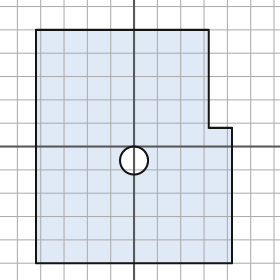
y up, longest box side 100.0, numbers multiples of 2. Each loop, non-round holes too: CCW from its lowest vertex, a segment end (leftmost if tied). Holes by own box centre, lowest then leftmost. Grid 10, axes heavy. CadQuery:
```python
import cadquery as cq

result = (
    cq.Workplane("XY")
    .moveTo(-42.0, -50.0)
    .lineTo(42.0, -50.0)
    .lineTo(42.0, 8.0)
    .lineTo(32.0, 8.0)
    .lineTo(32.0, 50.0)
    .lineTo(-42.0, 50.0)
    .close()
    .moveTo(0.0, -6.0)
    .circle(6.0)
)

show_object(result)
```